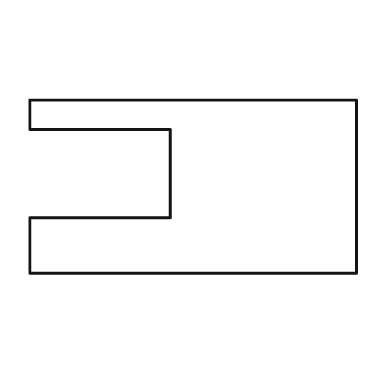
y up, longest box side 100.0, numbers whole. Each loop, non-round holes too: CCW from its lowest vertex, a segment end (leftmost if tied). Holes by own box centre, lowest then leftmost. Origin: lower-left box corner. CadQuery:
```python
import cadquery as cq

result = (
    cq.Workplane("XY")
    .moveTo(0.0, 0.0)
    .lineTo(100.0, 0.0)
    .lineTo(100.0, 53.0)
    .lineTo(0.0, 53.0)
    .lineTo(0.0, 44.0)
    .lineTo(43.0, 44.0)
    .lineTo(43.0, 17.0)
    .lineTo(0.0, 17.0)
    .close()
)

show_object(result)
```